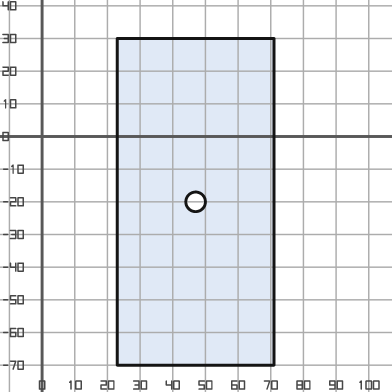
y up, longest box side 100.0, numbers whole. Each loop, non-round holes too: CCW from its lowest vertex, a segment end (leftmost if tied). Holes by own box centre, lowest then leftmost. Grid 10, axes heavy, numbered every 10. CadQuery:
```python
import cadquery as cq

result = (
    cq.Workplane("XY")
    .moveTo(23.0, -70.0)
    .lineTo(71.0, -70.0)
    .lineTo(71.0, 30.0)
    .lineTo(23.0, 30.0)
    .close()
    .moveTo(47.0, -20.0)
    .circle(3.0)
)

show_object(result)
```